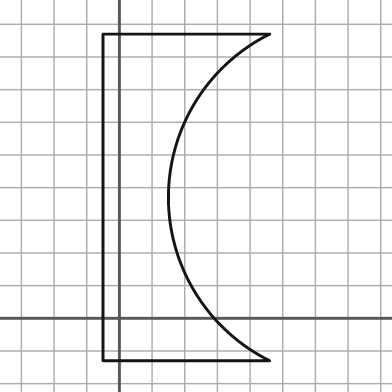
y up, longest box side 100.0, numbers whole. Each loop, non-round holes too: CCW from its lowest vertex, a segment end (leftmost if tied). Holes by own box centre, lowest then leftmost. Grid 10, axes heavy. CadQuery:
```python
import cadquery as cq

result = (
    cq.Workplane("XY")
    .moveTo(-5.0, -13.0)
    .lineTo(46.0, -13.0)
    .threePointArc((15.0, 37.0), (46.0, 87.0))
    .lineTo(-5.0, 87.0)
    .close()
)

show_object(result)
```